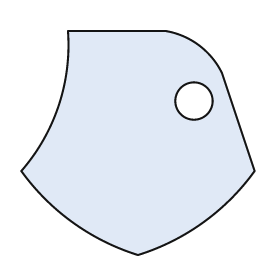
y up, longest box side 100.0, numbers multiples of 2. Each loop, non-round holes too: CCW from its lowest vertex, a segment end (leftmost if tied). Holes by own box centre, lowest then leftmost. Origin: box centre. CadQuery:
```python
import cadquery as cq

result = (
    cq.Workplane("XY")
    .moveTo(0.0, -48.0)
    .threePointArc((28.0, -34.0), (50.0, -12.0))
    .lineTo(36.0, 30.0)
    .threePointArc((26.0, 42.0), (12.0, 48.0))
    .lineTo(-30.0, 48.0)
    .threePointArc((-34.0, 16.0), (-50.0, -12.0))
    .threePointArc((-28.0, -34.0), (0.0, -48.0))
    .close()
    .moveTo(24.0, 18.0)
    .circle(8.0)
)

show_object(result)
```